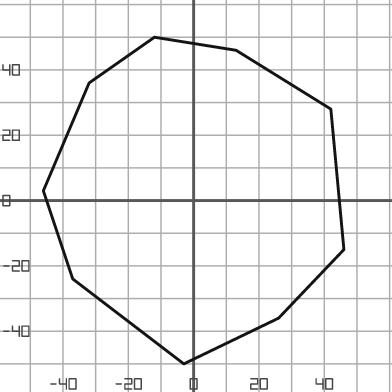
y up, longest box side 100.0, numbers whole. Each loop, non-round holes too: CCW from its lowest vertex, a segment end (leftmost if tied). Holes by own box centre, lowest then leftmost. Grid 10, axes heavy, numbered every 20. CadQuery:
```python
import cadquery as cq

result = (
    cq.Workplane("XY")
    .moveTo(-3.0, -50.0)
    .lineTo(26.0, -36.0)
    .lineTo(46.0, -15.0)
    .lineTo(42.0, 28.0)
    .lineTo(13.0, 46.0)
    .lineTo(-12.0, 50.0)
    .lineTo(-32.0, 36.0)
    .lineTo(-46.0, 3.0)
    .lineTo(-37.0, -24.0)
    .close()
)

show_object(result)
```